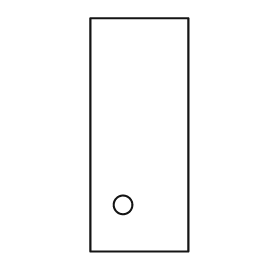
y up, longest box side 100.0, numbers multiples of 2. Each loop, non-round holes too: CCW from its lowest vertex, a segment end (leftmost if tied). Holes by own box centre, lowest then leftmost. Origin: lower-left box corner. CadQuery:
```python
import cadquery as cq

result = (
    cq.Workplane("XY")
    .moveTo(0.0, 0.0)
    .lineTo(42.0, 0.0)
    .lineTo(42.0, 100.0)
    .lineTo(0.0, 100.0)
    .close()
    .moveTo(14.0, 20.0)
    .circle(4.0)
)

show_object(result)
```